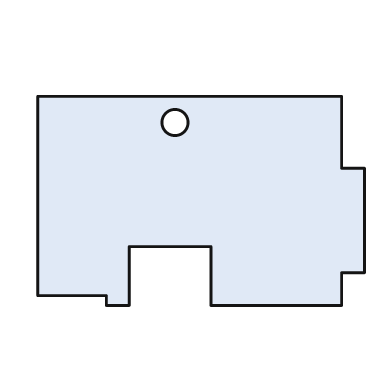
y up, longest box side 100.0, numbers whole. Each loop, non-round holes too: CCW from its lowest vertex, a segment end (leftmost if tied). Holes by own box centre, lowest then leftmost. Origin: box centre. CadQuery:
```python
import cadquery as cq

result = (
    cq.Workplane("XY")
    .moveTo(-29.0, -32.0)
    .lineTo(-22.0, -32.0)
    .lineTo(-22.0, -14.0)
    .lineTo(3.0, -14.0)
    .lineTo(3.0, -32.0)
    .lineTo(43.0, -32.0)
    .lineTo(43.0, -22.0)
    .lineTo(50.0, -22.0)
    .lineTo(50.0, 10.0)
    .lineTo(43.0, 10.0)
    .lineTo(43.0, 32.0)
    .lineTo(-50.0, 32.0)
    .lineTo(-50.0, -29.0)
    .lineTo(-29.0, -29.0)
    .close()
    .moveTo(-8.0, 24.0)
    .circle(4.0)
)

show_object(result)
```